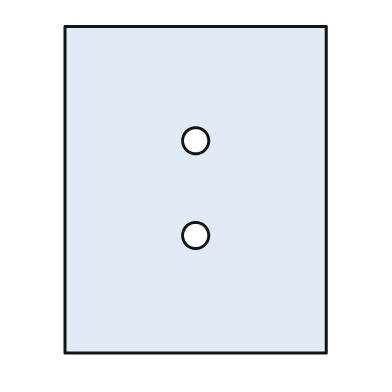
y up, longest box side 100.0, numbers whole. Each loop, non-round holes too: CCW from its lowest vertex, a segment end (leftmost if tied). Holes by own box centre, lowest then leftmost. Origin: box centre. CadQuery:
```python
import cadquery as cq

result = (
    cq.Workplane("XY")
    .moveTo(-40.0, -50.0)
    .lineTo(40.0, -50.0)
    .lineTo(40.0, 50.0)
    .lineTo(-40.0, 50.0)
    .close()
    .moveTo(0.0, -14.0)
    .circle(4.0)
    .moveTo(0.0, 15.0)
    .circle(4.0)
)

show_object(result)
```